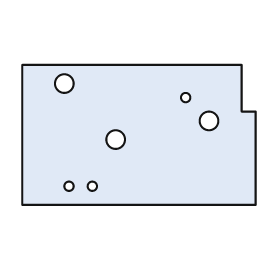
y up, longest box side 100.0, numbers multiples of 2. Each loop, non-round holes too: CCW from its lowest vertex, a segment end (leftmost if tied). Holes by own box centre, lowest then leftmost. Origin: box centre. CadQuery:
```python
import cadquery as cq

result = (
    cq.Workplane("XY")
    .moveTo(-50.0, -30.0)
    .lineTo(50.0, -30.0)
    .lineTo(50.0, 10.0)
    .lineTo(44.0, 10.0)
    .lineTo(44.0, 30.0)
    .lineTo(-50.0, 30.0)
    .close()
    .moveTo(-30.0, -22.0)
    .circle(2.0)
    .moveTo(-20.0, -22.0)
    .circle(2.0)
    .moveTo(-10.0, -2.0)
    .circle(4.0)
    .moveTo(30.0, 6.0)
    .circle(4.0)
    .moveTo(20.0, 16.0)
    .circle(2.0)
    .moveTo(-32.0, 22.0)
    .circle(4.0)
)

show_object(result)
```